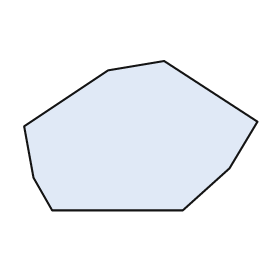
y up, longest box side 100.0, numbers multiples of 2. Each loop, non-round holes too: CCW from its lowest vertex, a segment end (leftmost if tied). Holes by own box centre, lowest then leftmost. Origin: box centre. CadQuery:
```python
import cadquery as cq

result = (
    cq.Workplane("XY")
    .moveTo(-38.0, -32.0)
    .lineTo(18.0, -32.0)
    .lineTo(38.0, -14.0)
    .lineTo(50.0, 6.0)
    .lineTo(10.0, 32.0)
    .lineTo(-14.0, 28.0)
    .lineTo(-50.0, 4.0)
    .lineTo(-46.0, -18.0)
    .close()
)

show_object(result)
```